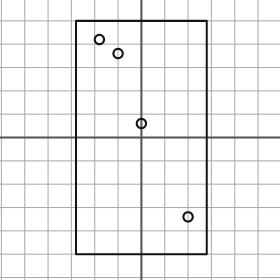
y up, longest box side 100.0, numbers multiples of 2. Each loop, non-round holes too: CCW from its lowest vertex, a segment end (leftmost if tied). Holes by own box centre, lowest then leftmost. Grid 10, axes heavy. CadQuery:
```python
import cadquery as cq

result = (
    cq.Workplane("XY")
    .moveTo(-28.0, -50.0)
    .lineTo(28.0, -50.0)
    .lineTo(28.0, 50.0)
    .lineTo(-28.0, 50.0)
    .close()
    .moveTo(20.0, -34.0)
    .circle(2.0)
    .moveTo(0.0, 6.0)
    .circle(2.0)
    .moveTo(-10.0, 36.0)
    .circle(2.0)
    .moveTo(-18.0, 42.0)
    .circle(2.0)
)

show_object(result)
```